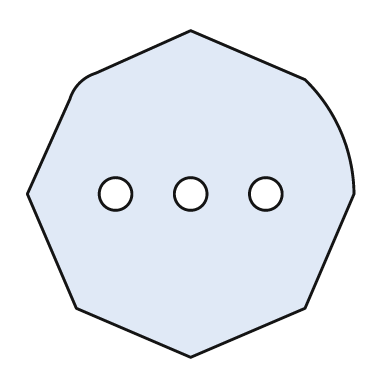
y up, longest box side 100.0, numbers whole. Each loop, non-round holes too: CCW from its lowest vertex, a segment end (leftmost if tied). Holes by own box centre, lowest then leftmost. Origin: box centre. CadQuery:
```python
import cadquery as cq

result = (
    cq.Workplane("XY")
    .moveTo(0.0, -50.0)
    .lineTo(35.0, -35.0)
    .lineTo(50.0, 0.0)
    .threePointArc((46.0, 19.0), (35.0, 35.0))
    .lineTo(0.0, 50.0)
    .lineTo(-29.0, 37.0)
    .threePointArc((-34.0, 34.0), (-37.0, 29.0))
    .lineTo(-50.0, 0.0)
    .lineTo(-35.0, -35.0)
    .close()
    .moveTo(-23.0, 0.0)
    .circle(5.0)
    .moveTo(0.0, 0.0)
    .circle(5.0)
    .moveTo(23.0, 0.0)
    .circle(5.0)
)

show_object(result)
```